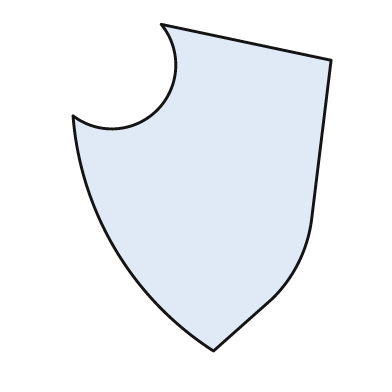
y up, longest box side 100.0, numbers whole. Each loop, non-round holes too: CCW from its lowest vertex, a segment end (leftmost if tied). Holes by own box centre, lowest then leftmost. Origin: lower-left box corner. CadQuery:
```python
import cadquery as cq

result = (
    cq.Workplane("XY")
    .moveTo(43.0, 0.0)
    .lineTo(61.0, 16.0)
    .threePointArc((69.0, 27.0), (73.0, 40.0))
    .lineTo(79.0, 89.0)
    .lineTo(27.0, 100.0)
    .threePointArc((26.0, 74.0), (0.0, 72.0))
    .threePointArc((13.0, 31.0), (43.0, 0.0))
    .close()
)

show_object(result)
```